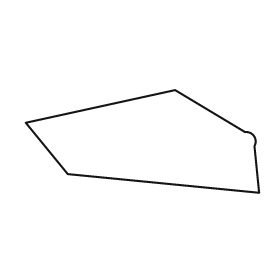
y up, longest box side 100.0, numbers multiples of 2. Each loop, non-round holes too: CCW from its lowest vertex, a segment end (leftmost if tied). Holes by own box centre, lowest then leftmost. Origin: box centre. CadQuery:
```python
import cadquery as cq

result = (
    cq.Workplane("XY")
    .moveTo(50.0, -22.0)
    .lineTo(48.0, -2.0)
    .threePointArc((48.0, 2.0), (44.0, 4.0))
    .lineTo(14.0, 22.0)
    .lineTo(-50.0, 8.0)
    .lineTo(-32.0, -14.0)
    .close()
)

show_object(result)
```